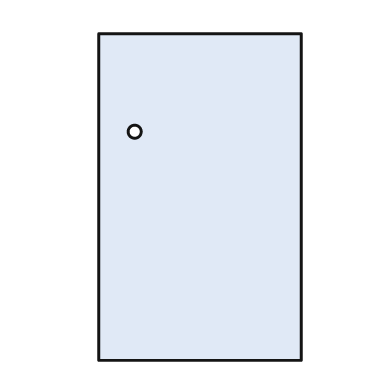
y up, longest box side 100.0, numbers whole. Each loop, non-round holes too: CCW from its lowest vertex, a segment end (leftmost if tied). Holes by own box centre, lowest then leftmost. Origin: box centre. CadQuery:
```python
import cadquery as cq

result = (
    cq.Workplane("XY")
    .moveTo(-31.0, -50.0)
    .lineTo(31.0, -50.0)
    .lineTo(31.0, 50.0)
    .lineTo(-31.0, 50.0)
    .close()
    .moveTo(-20.0, 20.0)
    .circle(2.0)
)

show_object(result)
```